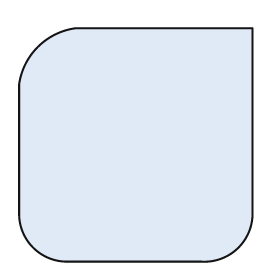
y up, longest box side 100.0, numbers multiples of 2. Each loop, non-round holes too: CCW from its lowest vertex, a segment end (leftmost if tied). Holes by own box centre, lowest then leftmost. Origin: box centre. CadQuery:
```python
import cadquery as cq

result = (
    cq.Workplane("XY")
    .moveTo(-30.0, -50.0)
    .lineTo(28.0, -50.0)
    .threePointArc((44.0, -44.0), (50.0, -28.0))
    .lineTo(50.0, 50.0)
    .lineTo(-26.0, 50.0)
    .threePointArc((-42.0, 42.0), (-50.0, 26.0))
    .lineTo(-50.0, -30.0)
    .threePointArc((-44.0, -44.0), (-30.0, -50.0))
    .close()
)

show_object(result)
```